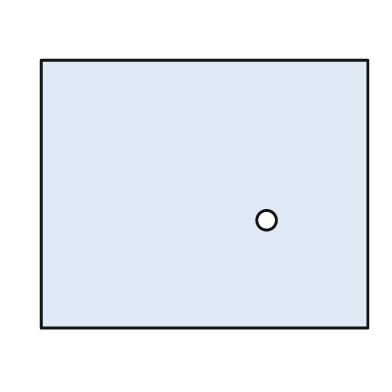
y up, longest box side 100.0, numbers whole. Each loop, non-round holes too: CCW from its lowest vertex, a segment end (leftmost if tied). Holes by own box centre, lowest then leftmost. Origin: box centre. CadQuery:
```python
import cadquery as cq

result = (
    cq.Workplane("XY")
    .moveTo(-50.0, -41.0)
    .lineTo(50.0, -41.0)
    .lineTo(50.0, 41.0)
    .lineTo(-50.0, 41.0)
    .close()
    .moveTo(19.0, -8.0)
    .circle(3.0)
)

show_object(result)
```